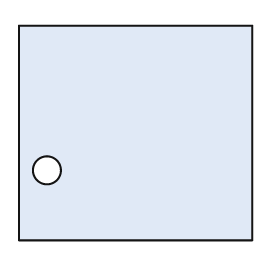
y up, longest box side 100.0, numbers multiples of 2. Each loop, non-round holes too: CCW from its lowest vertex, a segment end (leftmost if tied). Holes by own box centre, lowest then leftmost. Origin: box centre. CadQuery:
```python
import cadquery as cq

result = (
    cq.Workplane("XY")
    .moveTo(-50.0, -46.0)
    .lineTo(50.0, -46.0)
    .lineTo(50.0, 46.0)
    .lineTo(-50.0, 46.0)
    .close()
    .moveTo(-38.0, -16.0)
    .circle(6.0)
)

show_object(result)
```